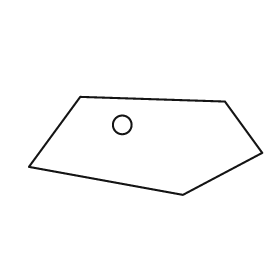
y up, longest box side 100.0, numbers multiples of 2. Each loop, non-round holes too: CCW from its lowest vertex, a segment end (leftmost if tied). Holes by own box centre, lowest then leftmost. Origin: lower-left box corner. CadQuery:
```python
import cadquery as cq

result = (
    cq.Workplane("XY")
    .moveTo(66.0, 0.0)
    .lineTo(100.0, 18.0)
    .lineTo(84.0, 40.0)
    .lineTo(22.0, 42.0)
    .lineTo(0.0, 12.0)
    .close()
    .moveTo(40.0, 30.0)
    .circle(4.0)
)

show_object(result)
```